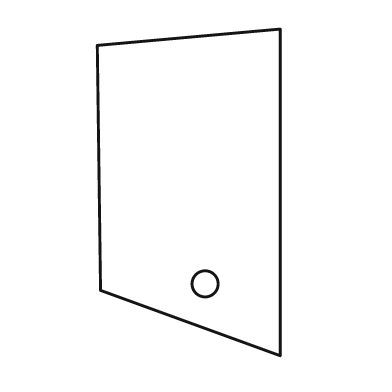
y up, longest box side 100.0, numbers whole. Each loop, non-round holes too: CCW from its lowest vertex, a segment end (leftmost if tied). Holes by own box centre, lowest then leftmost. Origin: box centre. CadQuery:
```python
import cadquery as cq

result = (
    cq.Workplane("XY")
    .moveTo(28.0, -50.0)
    .lineTo(28.0, 50.0)
    .lineTo(-28.0, 45.0)
    .lineTo(-27.0, -30.0)
    .close()
    .moveTo(5.0, -28.0)
    .circle(4.0)
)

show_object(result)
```